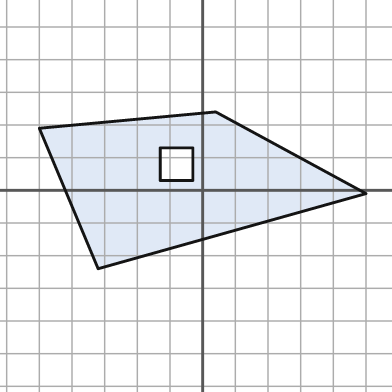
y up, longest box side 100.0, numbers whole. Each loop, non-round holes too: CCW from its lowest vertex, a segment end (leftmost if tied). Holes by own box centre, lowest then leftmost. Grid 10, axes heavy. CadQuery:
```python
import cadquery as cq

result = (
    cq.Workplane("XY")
    .moveTo(-32.0, -24.0)
    .lineTo(50.0, -1.0)
    .lineTo(4.0, 24.0)
    .lineTo(-50.0, 19.0)
    .close()
    .moveTo(-13.0, 3.0)
    .lineTo(-3.0, 3.0)
    .lineTo(-3.0, 13.0)
    .lineTo(-13.0, 13.0)
    .close()
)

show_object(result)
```